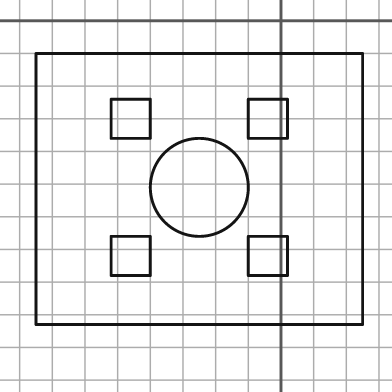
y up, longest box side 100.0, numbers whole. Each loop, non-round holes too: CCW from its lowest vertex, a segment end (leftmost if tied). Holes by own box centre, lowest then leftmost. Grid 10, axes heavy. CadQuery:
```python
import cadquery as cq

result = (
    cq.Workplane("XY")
    .moveTo(-75.0, -93.0)
    .lineTo(25.0, -93.0)
    .lineTo(25.0, -10.0)
    .lineTo(-75.0, -10.0)
    .close()
    .moveTo(-52.0, -78.0)
    .lineTo(-40.0, -78.0)
    .lineTo(-40.0, -66.0)
    .lineTo(-52.0, -66.0)
    .close()
    .moveTo(-10.0, -78.0)
    .lineTo(2.0, -78.0)
    .lineTo(2.0, -66.0)
    .lineTo(-10.0, -66.0)
    .close()
    .moveTo(-25.0, -51.0)
    .circle(15.0)
    .moveTo(-52.0, -36.0)
    .lineTo(-40.0, -36.0)
    .lineTo(-40.0, -24.0)
    .lineTo(-52.0, -24.0)
    .close()
    .moveTo(-10.0, -36.0)
    .lineTo(2.0, -36.0)
    .lineTo(2.0, -24.0)
    .lineTo(-10.0, -24.0)
    .close()
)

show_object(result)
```